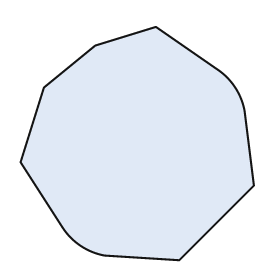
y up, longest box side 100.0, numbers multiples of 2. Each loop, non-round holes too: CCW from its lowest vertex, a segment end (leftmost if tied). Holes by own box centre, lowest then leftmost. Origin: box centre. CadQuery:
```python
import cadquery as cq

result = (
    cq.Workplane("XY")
    .moveTo(18.0, -50.0)
    .lineTo(50.0, -18.0)
    .lineTo(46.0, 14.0)
    .threePointArc((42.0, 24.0), (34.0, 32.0))
    .lineTo(8.0, 50.0)
    .lineTo(-18.0, 42.0)
    .lineTo(-40.0, 24.0)
    .lineTo(-50.0, -8.0)
    .lineTo(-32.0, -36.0)
    .threePointArc((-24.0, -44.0), (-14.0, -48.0))
    .close()
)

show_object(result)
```